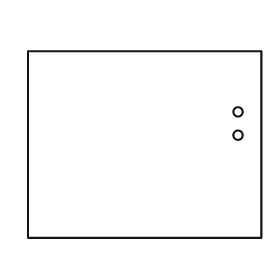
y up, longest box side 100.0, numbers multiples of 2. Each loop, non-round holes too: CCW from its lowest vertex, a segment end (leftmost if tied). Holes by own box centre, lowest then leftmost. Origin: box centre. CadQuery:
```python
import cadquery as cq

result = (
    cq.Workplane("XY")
    .moveTo(-50.0, -40.0)
    .lineTo(50.0, -40.0)
    .lineTo(50.0, 40.0)
    .lineTo(-50.0, 40.0)
    .close()
    .moveTo(40.0, 4.0)
    .circle(2.0)
    .moveTo(40.0, 14.0)
    .circle(2.0)
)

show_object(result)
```